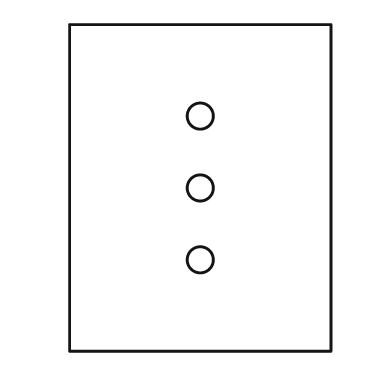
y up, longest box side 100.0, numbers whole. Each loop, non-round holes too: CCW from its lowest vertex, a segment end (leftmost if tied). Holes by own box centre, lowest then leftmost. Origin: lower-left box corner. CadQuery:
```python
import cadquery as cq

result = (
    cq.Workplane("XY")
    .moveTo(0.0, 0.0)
    .lineTo(80.0, 0.0)
    .lineTo(80.0, 100.0)
    .lineTo(0.0, 100.0)
    .close()
    .moveTo(40.0, 28.0)
    .circle(4.0)
    .moveTo(40.0, 50.0)
    .circle(4.0)
    .moveTo(40.0, 72.0)
    .circle(4.0)
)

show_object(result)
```